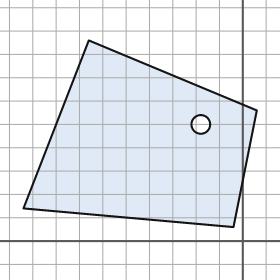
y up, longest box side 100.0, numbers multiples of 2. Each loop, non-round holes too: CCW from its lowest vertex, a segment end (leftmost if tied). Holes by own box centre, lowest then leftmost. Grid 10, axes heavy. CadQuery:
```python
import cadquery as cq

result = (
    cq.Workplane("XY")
    .moveTo(-4.0, 6.0)
    .lineTo(6.0, 56.0)
    .lineTo(-66.0, 86.0)
    .lineTo(-94.0, 14.0)
    .close()
    .moveTo(-18.0, 50.0)
    .circle(4.0)
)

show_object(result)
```